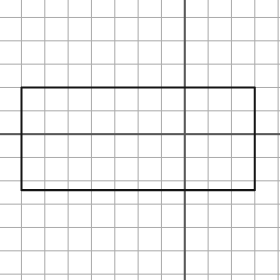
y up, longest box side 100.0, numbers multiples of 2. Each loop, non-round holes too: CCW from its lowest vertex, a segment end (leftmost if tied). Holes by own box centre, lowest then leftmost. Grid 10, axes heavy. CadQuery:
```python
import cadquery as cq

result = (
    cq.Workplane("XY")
    .moveTo(-70.0, -24.0)
    .lineTo(30.0, -24.0)
    .lineTo(30.0, 20.0)
    .lineTo(-70.0, 20.0)
    .close()
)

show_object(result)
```